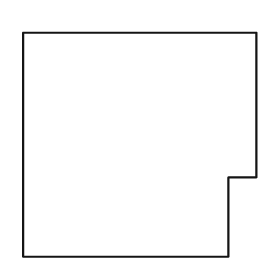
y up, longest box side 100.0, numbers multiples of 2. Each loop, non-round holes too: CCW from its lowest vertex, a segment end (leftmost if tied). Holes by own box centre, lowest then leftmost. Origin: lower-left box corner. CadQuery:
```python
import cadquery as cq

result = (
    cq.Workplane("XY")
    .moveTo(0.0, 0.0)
    .lineTo(88.0, 0.0)
    .lineTo(88.0, 34.0)
    .lineTo(100.0, 34.0)
    .lineTo(100.0, 96.0)
    .lineTo(0.0, 96.0)
    .close()
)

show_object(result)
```